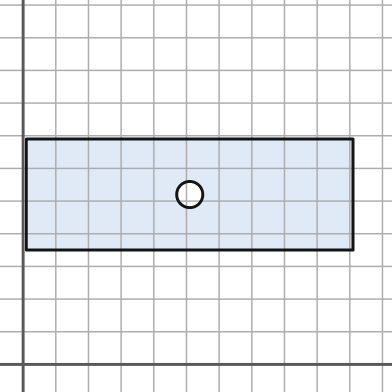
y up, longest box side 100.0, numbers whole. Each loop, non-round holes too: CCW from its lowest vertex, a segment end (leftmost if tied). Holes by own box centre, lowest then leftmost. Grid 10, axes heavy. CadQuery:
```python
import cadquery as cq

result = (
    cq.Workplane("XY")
    .moveTo(1.0, 35.0)
    .lineTo(101.0, 35.0)
    .lineTo(101.0, 69.0)
    .lineTo(1.0, 69.0)
    .close()
    .moveTo(51.0, 52.0)
    .circle(4.0)
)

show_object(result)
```